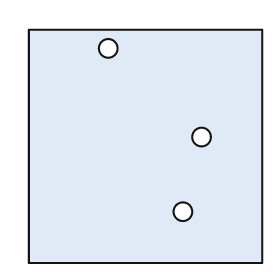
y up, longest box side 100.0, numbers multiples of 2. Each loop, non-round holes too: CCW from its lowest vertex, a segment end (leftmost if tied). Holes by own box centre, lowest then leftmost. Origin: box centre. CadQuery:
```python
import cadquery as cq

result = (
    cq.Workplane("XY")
    .moveTo(-50.0, -50.0)
    .lineTo(50.0, -50.0)
    .lineTo(50.0, 50.0)
    .lineTo(-50.0, 50.0)
    .close()
    .moveTo(16.0, -28.0)
    .circle(4.0)
    .moveTo(24.0, 4.0)
    .circle(4.0)
    .moveTo(-16.0, 42.0)
    .circle(4.0)
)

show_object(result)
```